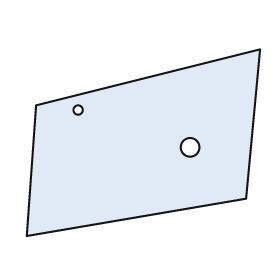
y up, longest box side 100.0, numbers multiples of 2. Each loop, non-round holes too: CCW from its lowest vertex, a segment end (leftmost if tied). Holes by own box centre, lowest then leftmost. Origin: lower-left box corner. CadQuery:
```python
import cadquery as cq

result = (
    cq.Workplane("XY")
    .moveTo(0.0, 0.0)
    .lineTo(94.0, 16.0)
    .lineTo(100.0, 80.0)
    .lineTo(4.0, 56.0)
    .close()
    .moveTo(70.0, 38.0)
    .circle(4.0)
    .moveTo(22.0, 54.0)
    .circle(2.0)
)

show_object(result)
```